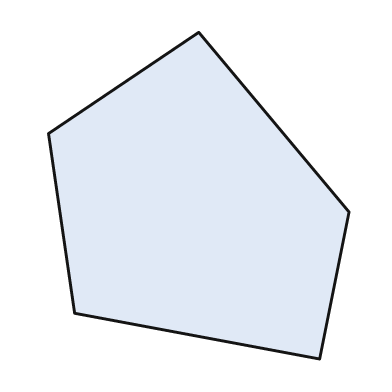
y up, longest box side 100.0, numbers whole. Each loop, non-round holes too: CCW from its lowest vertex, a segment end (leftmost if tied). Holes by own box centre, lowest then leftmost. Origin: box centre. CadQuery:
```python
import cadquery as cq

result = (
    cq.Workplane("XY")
    .moveTo(37.0, -50.0)
    .lineTo(46.0, -5.0)
    .lineTo(0.0, 50.0)
    .lineTo(-46.0, 19.0)
    .lineTo(-38.0, -36.0)
    .close()
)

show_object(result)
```